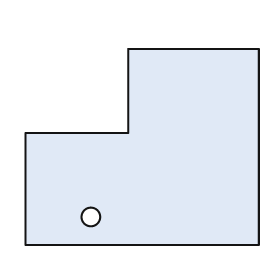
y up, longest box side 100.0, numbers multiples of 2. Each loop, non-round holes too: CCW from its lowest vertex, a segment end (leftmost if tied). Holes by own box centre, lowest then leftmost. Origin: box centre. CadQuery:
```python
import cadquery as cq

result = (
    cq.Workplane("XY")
    .moveTo(-50.0, -42.0)
    .lineTo(50.0, -42.0)
    .lineTo(50.0, 42.0)
    .lineTo(-6.0, 42.0)
    .lineTo(-6.0, 6.0)
    .lineTo(-50.0, 6.0)
    .close()
    .moveTo(-22.0, -30.0)
    .circle(4.0)
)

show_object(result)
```